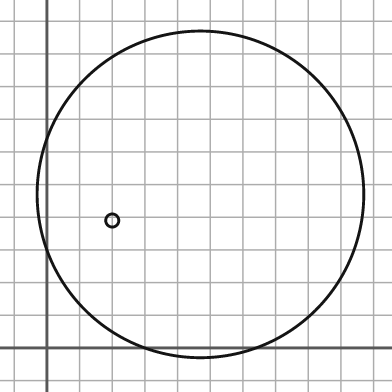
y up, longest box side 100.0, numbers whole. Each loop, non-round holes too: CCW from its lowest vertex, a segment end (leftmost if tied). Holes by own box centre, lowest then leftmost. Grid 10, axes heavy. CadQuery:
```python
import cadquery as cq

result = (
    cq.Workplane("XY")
    .moveTo(47.0, 47.0)
    .circle(50.0)
    .moveTo(20.0, 39.0)
    .circle(2.0)
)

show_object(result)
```